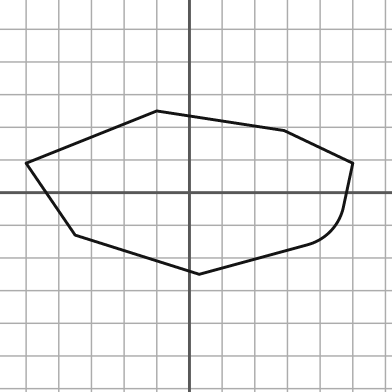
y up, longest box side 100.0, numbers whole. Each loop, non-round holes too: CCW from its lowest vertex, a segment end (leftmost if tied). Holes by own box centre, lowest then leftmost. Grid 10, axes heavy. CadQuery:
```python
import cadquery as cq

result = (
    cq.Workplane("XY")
    .moveTo(3.0, -25.0)
    .lineTo(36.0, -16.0)
    .threePointArc((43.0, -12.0), (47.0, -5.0))
    .lineTo(50.0, 9.0)
    .lineTo(29.0, 19.0)
    .lineTo(-10.0, 25.0)
    .lineTo(-50.0, 9.0)
    .lineTo(-35.0, -13.0)
    .close()
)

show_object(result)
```